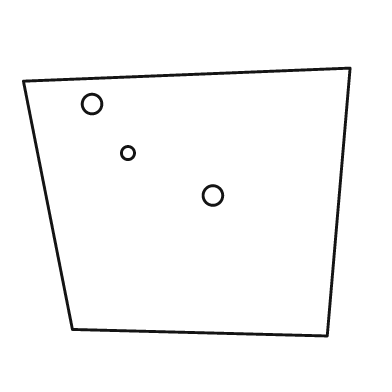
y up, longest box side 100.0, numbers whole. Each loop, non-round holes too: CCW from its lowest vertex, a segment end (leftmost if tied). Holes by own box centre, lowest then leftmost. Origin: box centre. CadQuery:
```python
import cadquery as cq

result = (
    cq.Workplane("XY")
    .moveTo(43.0, -41.0)
    .lineTo(50.0, 41.0)
    .lineTo(-50.0, 37.0)
    .lineTo(-35.0, -39.0)
    .close()
    .moveTo(8.0, 2.0)
    .circle(3.0)
    .moveTo(-18.0, 15.0)
    .circle(2.0)
    .moveTo(-29.0, 30.0)
    .circle(3.0)
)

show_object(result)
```